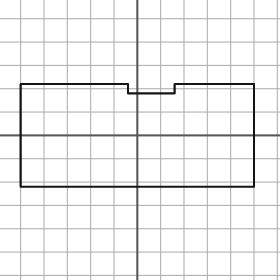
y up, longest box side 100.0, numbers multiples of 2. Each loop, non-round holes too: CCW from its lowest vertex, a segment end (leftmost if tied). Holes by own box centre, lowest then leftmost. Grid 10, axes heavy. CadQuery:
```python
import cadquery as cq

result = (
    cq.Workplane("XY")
    .moveTo(-50.0, -22.0)
    .lineTo(50.0, -22.0)
    .lineTo(50.0, 22.0)
    .lineTo(16.0, 22.0)
    .lineTo(16.0, 18.0)
    .lineTo(-4.0, 18.0)
    .lineTo(-4.0, 22.0)
    .lineTo(-50.0, 22.0)
    .close()
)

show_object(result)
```